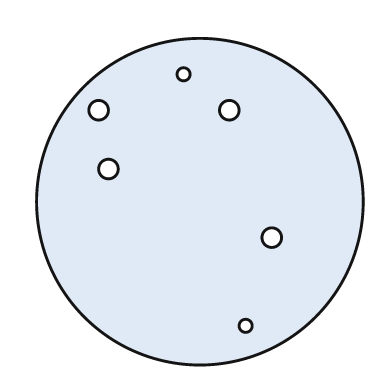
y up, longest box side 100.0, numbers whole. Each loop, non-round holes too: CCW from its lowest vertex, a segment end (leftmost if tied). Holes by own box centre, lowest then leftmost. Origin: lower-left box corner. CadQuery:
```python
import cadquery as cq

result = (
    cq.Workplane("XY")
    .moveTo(50.0, 50.0)
    .circle(50.0)
    .moveTo(64.0, 12.0)
    .circle(2.0)
    .moveTo(72.0, 39.0)
    .circle(3.0)
    .moveTo(22.0, 60.0)
    .circle(3.0)
    .moveTo(19.0, 78.0)
    .circle(3.0)
    .moveTo(59.0, 78.0)
    .circle(3.0)
    .moveTo(45.0, 89.0)
    .circle(2.0)
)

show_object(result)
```